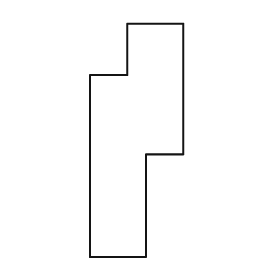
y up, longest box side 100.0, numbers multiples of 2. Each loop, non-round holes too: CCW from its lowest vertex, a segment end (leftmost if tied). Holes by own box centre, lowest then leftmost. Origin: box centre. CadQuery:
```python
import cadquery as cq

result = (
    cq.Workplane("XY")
    .moveTo(-20.0, -50.0)
    .lineTo(4.0, -50.0)
    .lineTo(4.0, -6.0)
    .lineTo(20.0, -6.0)
    .lineTo(20.0, 50.0)
    .lineTo(-4.0, 50.0)
    .lineTo(-4.0, 28.0)
    .lineTo(-20.0, 28.0)
    .close()
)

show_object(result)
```